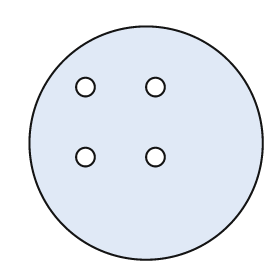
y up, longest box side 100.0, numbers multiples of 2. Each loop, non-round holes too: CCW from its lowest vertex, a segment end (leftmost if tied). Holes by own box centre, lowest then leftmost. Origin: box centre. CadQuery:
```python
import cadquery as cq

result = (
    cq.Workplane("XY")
    .moveTo(0.0, 0.0)
    .circle(50.0)
    .moveTo(-26.0, -6.0)
    .circle(4.0)
    .moveTo(4.0, -6.0)
    .circle(4.0)
    .moveTo(-26.0, 24.0)
    .circle(4.0)
    .moveTo(4.0, 24.0)
    .circle(4.0)
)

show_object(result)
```